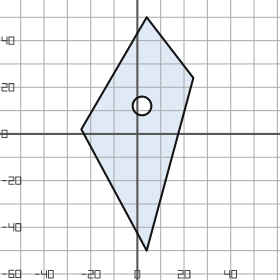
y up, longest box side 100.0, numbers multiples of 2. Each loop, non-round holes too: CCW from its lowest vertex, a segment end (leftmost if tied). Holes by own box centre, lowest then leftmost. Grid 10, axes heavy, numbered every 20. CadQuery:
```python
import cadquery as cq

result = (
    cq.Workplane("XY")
    .moveTo(4.0, -50.0)
    .lineTo(24.0, 24.0)
    .lineTo(4.0, 50.0)
    .lineTo(-24.0, 2.0)
    .close()
    .moveTo(2.0, 12.0)
    .circle(4.0)
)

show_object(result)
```